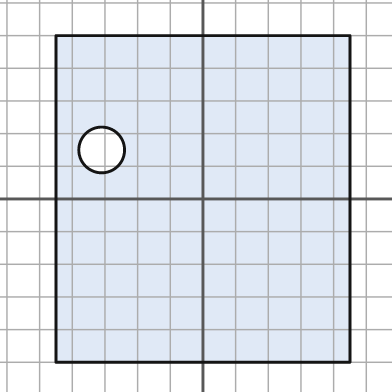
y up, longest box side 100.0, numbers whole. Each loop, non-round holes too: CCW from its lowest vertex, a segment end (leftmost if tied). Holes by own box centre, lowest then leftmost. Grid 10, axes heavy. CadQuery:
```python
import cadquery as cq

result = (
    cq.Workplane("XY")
    .moveTo(-45.0, -50.0)
    .lineTo(45.0, -50.0)
    .lineTo(45.0, 50.0)
    .lineTo(-45.0, 50.0)
    .close()
    .moveTo(-31.0, 15.0)
    .circle(7.0)
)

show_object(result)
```